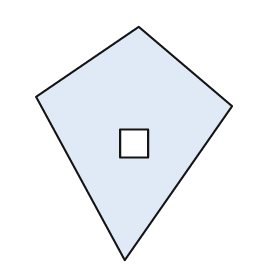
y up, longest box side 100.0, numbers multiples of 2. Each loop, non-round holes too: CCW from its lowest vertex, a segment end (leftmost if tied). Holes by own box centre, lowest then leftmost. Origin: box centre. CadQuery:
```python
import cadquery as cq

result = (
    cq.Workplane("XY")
    .moveTo(-4.0, -50.0)
    .lineTo(42.0, 16.0)
    .lineTo(2.0, 50.0)
    .lineTo(-42.0, 20.0)
    .close()
    .moveTo(-6.0, -6.0)
    .lineTo(6.0, -6.0)
    .lineTo(6.0, 6.0)
    .lineTo(-6.0, 6.0)
    .close()
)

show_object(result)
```